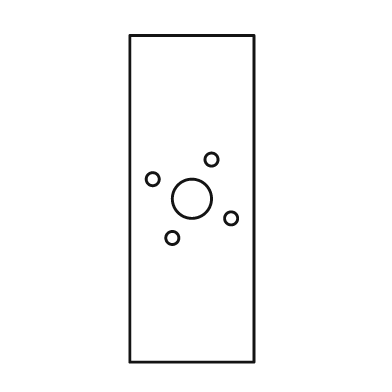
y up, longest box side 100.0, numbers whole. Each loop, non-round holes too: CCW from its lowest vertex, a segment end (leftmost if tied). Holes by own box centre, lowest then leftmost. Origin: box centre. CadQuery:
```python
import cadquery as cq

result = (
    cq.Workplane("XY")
    .moveTo(-19.0, -50.0)
    .lineTo(19.0, -50.0)
    .lineTo(19.0, 50.0)
    .lineTo(-19.0, 50.0)
    .close()
    .moveTo(-6.0, -12.0)
    .circle(2.0)
    .moveTo(12.0, -6.0)
    .circle(2.0)
    .moveTo(0.0, 0.0)
    .circle(6.0)
    .moveTo(-12.0, 6.0)
    .circle(2.0)
    .moveTo(6.0, 12.0)
    .circle(2.0)
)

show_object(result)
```